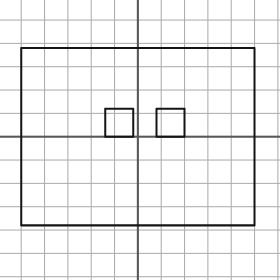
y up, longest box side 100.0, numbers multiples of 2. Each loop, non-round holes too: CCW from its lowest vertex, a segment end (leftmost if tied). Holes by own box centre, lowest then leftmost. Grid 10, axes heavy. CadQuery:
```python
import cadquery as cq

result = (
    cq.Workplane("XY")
    .moveTo(-50.0, -38.0)
    .lineTo(50.0, -38.0)
    .lineTo(50.0, 38.0)
    .lineTo(-50.0, 38.0)
    .close()
    .moveTo(-14.0, 0.0)
    .lineTo(-2.0, 0.0)
    .lineTo(-2.0, 12.0)
    .lineTo(-14.0, 12.0)
    .close()
    .moveTo(8.0, 0.0)
    .lineTo(20.0, 0.0)
    .lineTo(20.0, 12.0)
    .lineTo(8.0, 12.0)
    .close()
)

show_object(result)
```